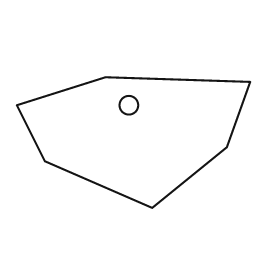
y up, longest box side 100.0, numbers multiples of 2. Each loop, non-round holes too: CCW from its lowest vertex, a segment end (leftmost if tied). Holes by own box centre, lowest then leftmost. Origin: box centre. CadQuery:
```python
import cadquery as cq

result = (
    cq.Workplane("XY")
    .moveTo(8.0, -28.0)
    .lineTo(40.0, -2.0)
    .lineTo(50.0, 26.0)
    .lineTo(-12.0, 28.0)
    .lineTo(-50.0, 16.0)
    .lineTo(-38.0, -8.0)
    .close()
    .moveTo(-2.0, 16.0)
    .circle(4.0)
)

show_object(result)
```